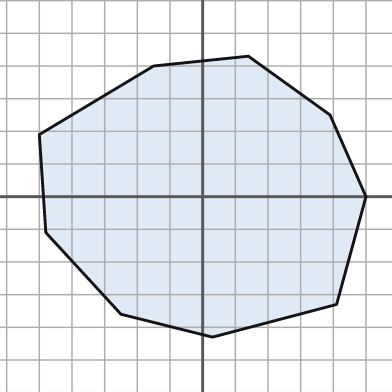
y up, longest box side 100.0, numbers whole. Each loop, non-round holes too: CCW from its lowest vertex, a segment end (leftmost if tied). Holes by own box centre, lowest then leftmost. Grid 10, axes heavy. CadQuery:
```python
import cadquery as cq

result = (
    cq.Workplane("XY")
    .moveTo(3.0, -43.0)
    .lineTo(41.0, -33.0)
    .lineTo(50.0, 0.0)
    .lineTo(39.0, 25.0)
    .lineTo(14.0, 43.0)
    .lineTo(-15.0, 40.0)
    .lineTo(-50.0, 19.0)
    .lineTo(-48.0, -11.0)
    .lineTo(-25.0, -36.0)
    .close()
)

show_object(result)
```